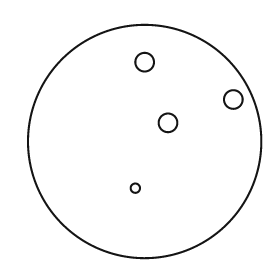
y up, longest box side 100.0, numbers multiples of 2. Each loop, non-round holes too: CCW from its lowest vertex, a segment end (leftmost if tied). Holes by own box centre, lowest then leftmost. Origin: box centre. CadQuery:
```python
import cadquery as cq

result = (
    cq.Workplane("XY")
    .moveTo(0.0, 0.0)
    .circle(50.0)
    .moveTo(-4.0, -20.0)
    .circle(2.0)
    .moveTo(10.0, 8.0)
    .circle(4.0)
    .moveTo(38.0, 18.0)
    .circle(4.0)
    .moveTo(0.0, 34.0)
    .circle(4.0)
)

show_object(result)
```